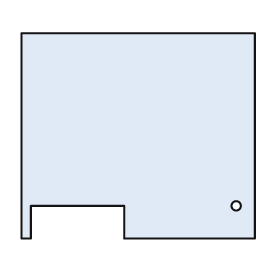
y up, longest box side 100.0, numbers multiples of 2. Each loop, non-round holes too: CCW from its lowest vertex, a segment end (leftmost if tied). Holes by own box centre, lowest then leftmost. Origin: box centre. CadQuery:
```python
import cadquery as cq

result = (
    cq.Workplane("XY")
    .moveTo(-50.0, -44.0)
    .lineTo(-46.0, -44.0)
    .lineTo(-46.0, -30.0)
    .lineTo(-6.0, -30.0)
    .lineTo(-6.0, -44.0)
    .lineTo(50.0, -44.0)
    .lineTo(50.0, 44.0)
    .lineTo(-50.0, 44.0)
    .close()
    .moveTo(42.0, -30.0)
    .circle(2.0)
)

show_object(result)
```